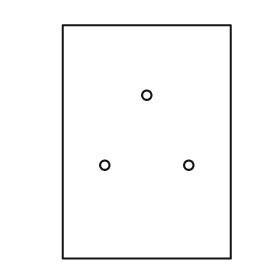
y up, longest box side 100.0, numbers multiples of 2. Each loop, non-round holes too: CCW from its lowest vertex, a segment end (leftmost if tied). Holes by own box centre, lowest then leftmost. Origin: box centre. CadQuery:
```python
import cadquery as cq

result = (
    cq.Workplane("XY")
    .moveTo(-36.0, -50.0)
    .lineTo(36.0, -50.0)
    .lineTo(36.0, 50.0)
    .lineTo(-36.0, 50.0)
    .close()
    .moveTo(-18.0, -10.0)
    .circle(2.0)
    .moveTo(18.0, -10.0)
    .circle(2.0)
    .moveTo(0.0, 20.0)
    .circle(2.0)
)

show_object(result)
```